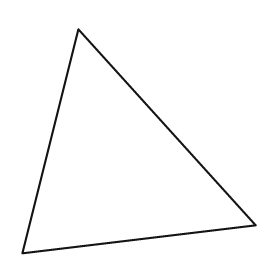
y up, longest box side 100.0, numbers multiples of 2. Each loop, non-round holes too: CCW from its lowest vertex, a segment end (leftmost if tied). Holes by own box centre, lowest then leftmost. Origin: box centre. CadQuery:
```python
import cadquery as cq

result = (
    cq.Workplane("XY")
    .moveTo(-50.0, -48.0)
    .lineTo(50.0, -36.0)
    .lineTo(-26.0, 48.0)
    .close()
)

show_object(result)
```